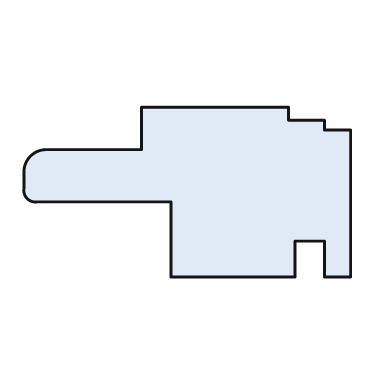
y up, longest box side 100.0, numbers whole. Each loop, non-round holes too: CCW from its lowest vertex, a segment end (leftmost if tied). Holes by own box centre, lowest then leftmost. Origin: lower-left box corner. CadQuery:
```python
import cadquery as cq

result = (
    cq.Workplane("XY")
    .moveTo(45.0, 0.0)
    .lineTo(83.0, 0.0)
    .lineTo(83.0, 11.0)
    .lineTo(92.0, 11.0)
    .lineTo(92.0, 0.0)
    .lineTo(100.0, 0.0)
    .lineTo(100.0, 45.0)
    .lineTo(92.0, 45.0)
    .lineTo(92.0, 48.0)
    .lineTo(81.0, 48.0)
    .lineTo(81.0, 52.0)
    .lineTo(36.0, 52.0)
    .lineTo(36.0, 39.0)
    .lineTo(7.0, 39.0)
    .threePointArc((2.0, 37.0), (0.0, 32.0))
    .lineTo(0.0, 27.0)
    .threePointArc((1.0, 24.0), (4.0, 23.0))
    .lineTo(45.0, 23.0)
    .close()
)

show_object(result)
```